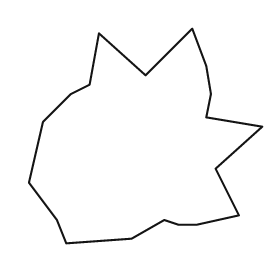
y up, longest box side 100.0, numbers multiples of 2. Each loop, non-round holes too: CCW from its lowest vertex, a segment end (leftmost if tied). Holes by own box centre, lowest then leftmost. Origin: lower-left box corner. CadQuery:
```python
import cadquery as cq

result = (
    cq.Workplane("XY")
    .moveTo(16.0, 0.0)
    .lineTo(44.0, 2.0)
    .lineTo(58.0, 10.0)
    .lineTo(64.0, 8.0)
    .lineTo(72.0, 8.0)
    .lineTo(90.0, 12.0)
    .lineTo(80.0, 32.0)
    .lineTo(100.0, 50.0)
    .lineTo(76.0, 54.0)
    .lineTo(78.0, 64.0)
    .lineTo(76.0, 76.0)
    .lineTo(70.0, 92.0)
    .lineTo(50.0, 72.0)
    .lineTo(30.0, 90.0)
    .lineTo(26.0, 68.0)
    .lineTo(18.0, 64.0)
    .lineTo(6.0, 52.0)
    .lineTo(0.0, 26.0)
    .lineTo(12.0, 10.0)
    .close()
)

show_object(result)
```